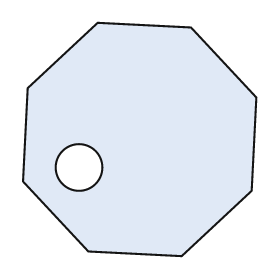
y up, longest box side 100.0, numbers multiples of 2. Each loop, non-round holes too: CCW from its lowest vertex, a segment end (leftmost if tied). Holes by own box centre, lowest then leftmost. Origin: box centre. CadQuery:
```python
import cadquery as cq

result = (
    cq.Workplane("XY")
    .moveTo(18.0, -50.0)
    .lineTo(48.0, -22.0)
    .lineTo(50.0, 18.0)
    .lineTo(22.0, 48.0)
    .lineTo(-18.0, 50.0)
    .lineTo(-48.0, 22.0)
    .lineTo(-50.0, -18.0)
    .lineTo(-22.0, -48.0)
    .close()
    .moveTo(-26.0, -12.0)
    .circle(10.0)
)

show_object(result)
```